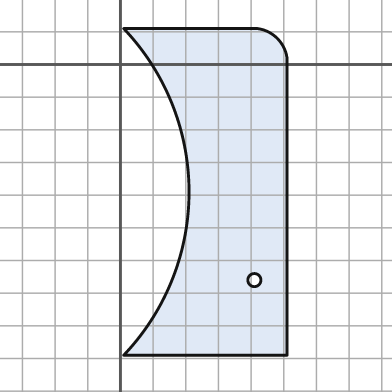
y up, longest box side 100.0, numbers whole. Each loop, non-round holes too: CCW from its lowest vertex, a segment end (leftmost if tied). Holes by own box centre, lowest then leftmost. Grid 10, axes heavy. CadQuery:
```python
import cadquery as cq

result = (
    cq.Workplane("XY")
    .moveTo(1.0, -89.0)
    .lineTo(51.0, -89.0)
    .lineTo(51.0, 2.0)
    .threePointArc((48.0, 8.0), (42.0, 11.0))
    .lineTo(1.0, 11.0)
    .threePointArc((21.0, -39.0), (1.0, -89.0))
    .close()
    .moveTo(41.0, -66.0)
    .circle(2.0)
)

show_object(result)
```